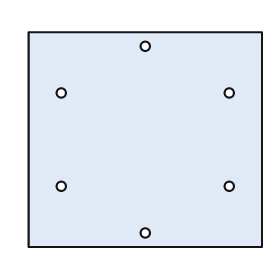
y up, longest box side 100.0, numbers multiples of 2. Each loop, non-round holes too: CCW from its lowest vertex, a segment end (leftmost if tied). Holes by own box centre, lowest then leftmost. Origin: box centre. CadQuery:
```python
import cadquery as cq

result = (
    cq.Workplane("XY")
    .moveTo(-50.0, -46.0)
    .lineTo(50.0, -46.0)
    .lineTo(50.0, 46.0)
    .lineTo(-50.0, 46.0)
    .close()
    .moveTo(0.0, -40.0)
    .circle(2.0)
    .moveTo(-36.0, -20.0)
    .circle(2.0)
    .moveTo(36.0, -20.0)
    .circle(2.0)
    .moveTo(-36.0, 20.0)
    .circle(2.0)
    .moveTo(36.0, 20.0)
    .circle(2.0)
    .moveTo(0.0, 40.0)
    .circle(2.0)
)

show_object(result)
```